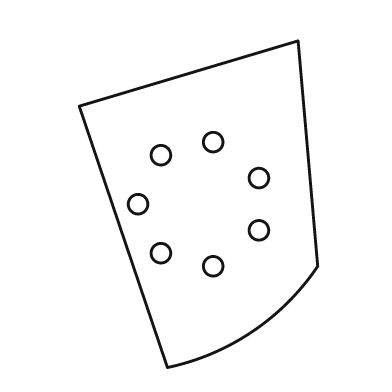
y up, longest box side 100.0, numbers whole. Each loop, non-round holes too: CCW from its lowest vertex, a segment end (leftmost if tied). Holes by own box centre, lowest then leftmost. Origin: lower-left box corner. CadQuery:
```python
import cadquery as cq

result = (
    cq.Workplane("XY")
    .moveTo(27.0, 0.0)
    .threePointArc((53.0, 11.0), (73.0, 31.0))
    .lineTo(67.0, 100.0)
    .lineTo(0.0, 80.0)
    .close()
    .moveTo(41.0, 31.0)
    .circle(3.0)
    .moveTo(25.0, 35.0)
    .circle(3.0)
    .moveTo(55.0, 42.0)
    .circle(3.0)
    .moveTo(18.0, 50.0)
    .circle(3.0)
    .moveTo(55.0, 58.0)
    .circle(3.0)
    .moveTo(25.0, 65.0)
    .circle(3.0)
    .moveTo(41.0, 69.0)
    .circle(3.0)
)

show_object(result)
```